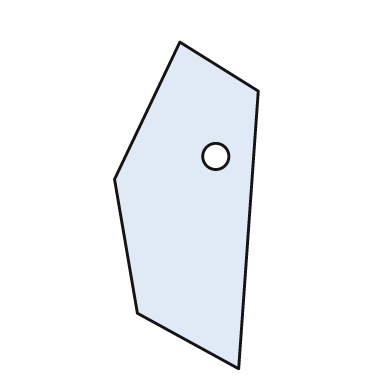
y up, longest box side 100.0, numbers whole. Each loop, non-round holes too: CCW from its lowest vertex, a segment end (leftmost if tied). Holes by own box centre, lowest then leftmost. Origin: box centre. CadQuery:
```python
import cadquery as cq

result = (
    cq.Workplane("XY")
    .moveTo(16.0, -50.0)
    .lineTo(22.0, 35.0)
    .lineTo(-2.0, 50.0)
    .lineTo(-22.0, 8.0)
    .lineTo(-15.0, -33.0)
    .close()
    .moveTo(9.0, 15.0)
    .circle(4.0)
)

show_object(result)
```